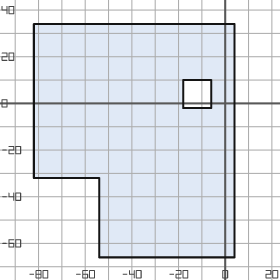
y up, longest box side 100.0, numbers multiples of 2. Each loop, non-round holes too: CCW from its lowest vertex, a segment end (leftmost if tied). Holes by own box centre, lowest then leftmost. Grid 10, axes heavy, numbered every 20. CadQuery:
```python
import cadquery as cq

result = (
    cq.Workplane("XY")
    .moveTo(-54.0, -66.0)
    .lineTo(4.0, -66.0)
    .lineTo(4.0, 34.0)
    .lineTo(-82.0, 34.0)
    .lineTo(-82.0, -32.0)
    .lineTo(-54.0, -32.0)
    .close()
    .moveTo(-18.0, -2.0)
    .lineTo(-6.0, -2.0)
    .lineTo(-6.0, 10.0)
    .lineTo(-18.0, 10.0)
    .close()
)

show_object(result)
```